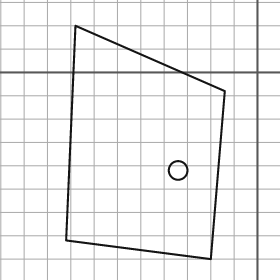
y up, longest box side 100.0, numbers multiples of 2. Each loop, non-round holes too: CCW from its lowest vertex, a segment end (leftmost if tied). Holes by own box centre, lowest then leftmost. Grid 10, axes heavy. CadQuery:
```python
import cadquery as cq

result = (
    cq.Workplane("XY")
    .moveTo(-20.0, -80.0)
    .lineTo(-14.0, -8.0)
    .lineTo(-78.0, 20.0)
    .lineTo(-82.0, -72.0)
    .close()
    .moveTo(-34.0, -42.0)
    .circle(4.0)
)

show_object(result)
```